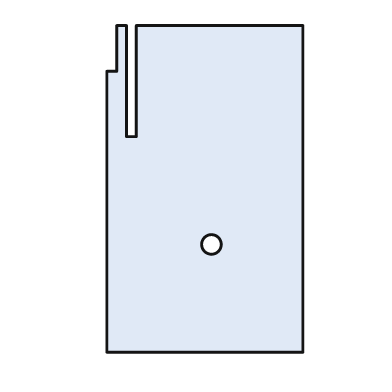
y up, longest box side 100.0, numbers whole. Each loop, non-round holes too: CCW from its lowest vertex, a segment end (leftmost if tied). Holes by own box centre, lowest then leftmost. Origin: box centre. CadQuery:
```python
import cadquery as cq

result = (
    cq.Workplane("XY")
    .moveTo(-30.0, -50.0)
    .lineTo(30.0, -50.0)
    .lineTo(30.0, 50.0)
    .lineTo(-21.0, 50.0)
    .lineTo(-21.0, 16.0)
    .lineTo(-24.0, 16.0)
    .lineTo(-24.0, 50.0)
    .lineTo(-27.0, 50.0)
    .lineTo(-27.0, 36.0)
    .lineTo(-30.0, 36.0)
    .close()
    .moveTo(2.0, -17.0)
    .circle(3.0)
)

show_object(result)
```